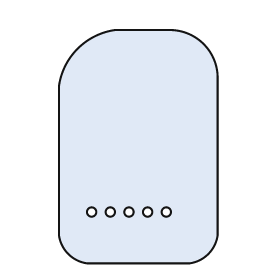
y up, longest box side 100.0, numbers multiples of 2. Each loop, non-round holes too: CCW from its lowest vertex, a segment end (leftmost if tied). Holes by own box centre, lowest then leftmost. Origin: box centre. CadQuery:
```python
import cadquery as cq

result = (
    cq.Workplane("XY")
    .moveTo(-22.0, -50.0)
    .lineTo(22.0, -50.0)
    .threePointArc((30.0, -46.0), (34.0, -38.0))
    .lineTo(34.0, 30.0)
    .threePointArc((28.0, 44.0), (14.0, 50.0))
    .lineTo(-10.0, 50.0)
    .threePointArc((-26.0, 42.0), (-34.0, 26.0))
    .lineTo(-34.0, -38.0)
    .threePointArc((-30.0, -46.0), (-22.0, -50.0))
    .close()
    .moveTo(-20.0, -28.0)
    .circle(2.0)
    .moveTo(-12.0, -28.0)
    .circle(2.0)
    .moveTo(-4.0, -28.0)
    .circle(2.0)
    .moveTo(4.0, -28.0)
    .circle(2.0)
    .moveTo(12.0, -28.0)
    .circle(2.0)
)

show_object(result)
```